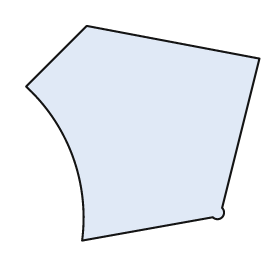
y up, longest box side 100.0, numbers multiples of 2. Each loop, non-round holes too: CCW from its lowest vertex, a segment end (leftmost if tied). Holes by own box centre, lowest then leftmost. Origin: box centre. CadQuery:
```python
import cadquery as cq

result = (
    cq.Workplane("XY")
    .moveTo(-26.0, -46.0)
    .lineTo(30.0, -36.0)
    .threePointArc((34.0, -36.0), (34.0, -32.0))
    .lineTo(50.0, 32.0)
    .lineTo(-24.0, 46.0)
    .lineTo(-50.0, 20.0)
    .threePointArc((-30.0, -10.0), (-26.0, -46.0))
    .close()
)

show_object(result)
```